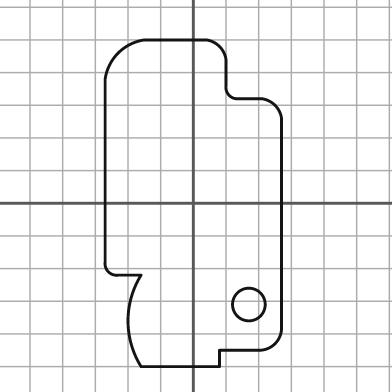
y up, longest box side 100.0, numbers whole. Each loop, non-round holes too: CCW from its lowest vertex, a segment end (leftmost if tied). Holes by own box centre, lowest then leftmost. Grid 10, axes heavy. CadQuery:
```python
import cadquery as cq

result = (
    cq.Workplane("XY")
    .moveTo(-16.0, -50.0)
    .lineTo(8.0, -50.0)
    .lineTo(8.0, -45.0)
    .lineTo(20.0, -45.0)
    .threePointArc((25.0, -43.0), (27.0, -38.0))
    .lineTo(27.0, 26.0)
    .threePointArc((25.0, 30.0), (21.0, 32.0))
    .lineTo(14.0, 32.0)
    .threePointArc((11.0, 33.0), (10.0, 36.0))
    .lineTo(10.0, 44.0)
    .threePointArc((8.0, 48.0), (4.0, 50.0))
    .lineTo(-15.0, 50.0)
    .threePointArc((-23.0, 46.0), (-27.0, 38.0))
    .lineTo(-27.0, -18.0)
    .threePointArc((-26.0, -21.0), (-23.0, -22.0))
    .lineTo(-16.0, -22.0)
    .threePointArc((-20.0, -36.0), (-16.0, -50.0))
    .close()
    .moveTo(17.0, -31.0)
    .circle(5.0)
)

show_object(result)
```